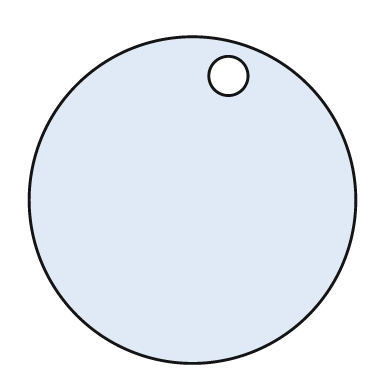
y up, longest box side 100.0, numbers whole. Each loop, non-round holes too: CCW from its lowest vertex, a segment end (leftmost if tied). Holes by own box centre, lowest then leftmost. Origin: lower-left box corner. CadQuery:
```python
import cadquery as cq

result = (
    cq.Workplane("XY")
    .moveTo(50.0, 50.0)
    .circle(50.0)
    .moveTo(61.0, 88.0)
    .circle(6.0)
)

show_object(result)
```